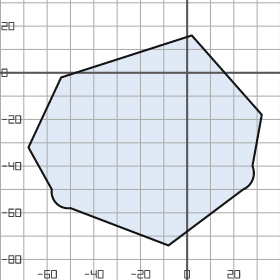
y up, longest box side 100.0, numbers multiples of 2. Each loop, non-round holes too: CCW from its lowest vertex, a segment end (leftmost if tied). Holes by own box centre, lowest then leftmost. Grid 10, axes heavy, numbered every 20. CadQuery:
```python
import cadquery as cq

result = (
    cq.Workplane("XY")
    .moveTo(-8.0, -74.0)
    .lineTo(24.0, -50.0)
    .threePointArc((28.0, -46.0), (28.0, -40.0))
    .lineTo(32.0, -18.0)
    .lineTo(2.0, 16.0)
    .lineTo(-54.0, -2.0)
    .lineTo(-68.0, -32.0)
    .lineTo(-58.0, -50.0)
    .threePointArc((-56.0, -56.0), (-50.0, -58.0))
    .close()
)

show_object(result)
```